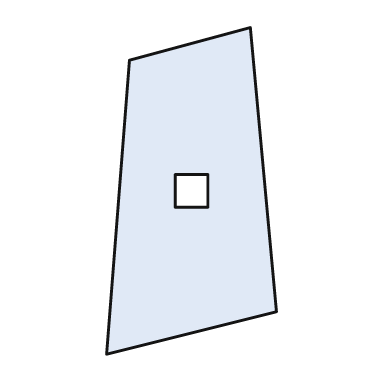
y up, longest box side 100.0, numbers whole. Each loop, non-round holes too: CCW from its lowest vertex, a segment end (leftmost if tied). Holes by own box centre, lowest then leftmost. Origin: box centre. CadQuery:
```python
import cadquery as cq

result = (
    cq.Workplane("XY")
    .moveTo(-26.0, -50.0)
    .lineTo(26.0, -37.0)
    .lineTo(18.0, 50.0)
    .lineTo(-19.0, 40.0)
    .close()
    .moveTo(-5.0, -5.0)
    .lineTo(5.0, -5.0)
    .lineTo(5.0, 5.0)
    .lineTo(-5.0, 5.0)
    .close()
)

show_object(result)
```